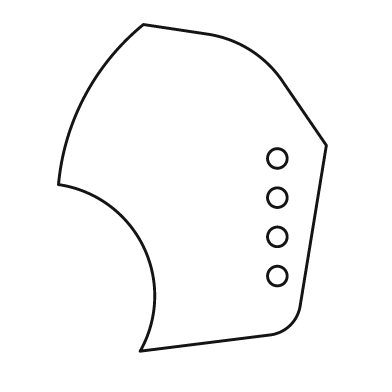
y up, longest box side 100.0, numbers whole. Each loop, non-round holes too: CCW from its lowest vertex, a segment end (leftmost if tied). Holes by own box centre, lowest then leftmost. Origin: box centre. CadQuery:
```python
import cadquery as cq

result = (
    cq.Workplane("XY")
    .moveTo(-16.0, -50.0)
    .lineTo(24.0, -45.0)
    .threePointArc((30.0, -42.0), (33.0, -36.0))
    .lineTo(41.0, 13.0)
    .lineTo(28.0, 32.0)
    .threePointArc((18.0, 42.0), (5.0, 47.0))
    .lineTo(-15.0, 50.0)
    .threePointArc((-33.0, 28.0), (-41.0, 1.0))
    .threePointArc((-15.0, -18.0), (-16.0, -50.0))
    .close()
    .moveTo(26.0, -27.0)
    .circle(3.0)
    .moveTo(26.0, -15.0)
    .circle(3.0)
    .moveTo(26.0, -3.0)
    .circle(3.0)
    .moveTo(26.0, 9.0)
    .circle(3.0)
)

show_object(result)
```